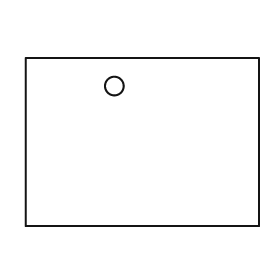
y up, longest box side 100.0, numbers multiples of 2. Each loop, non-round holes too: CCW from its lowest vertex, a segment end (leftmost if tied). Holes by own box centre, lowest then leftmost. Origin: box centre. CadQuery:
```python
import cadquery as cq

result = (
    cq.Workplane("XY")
    .moveTo(-50.0, -36.0)
    .lineTo(50.0, -36.0)
    .lineTo(50.0, 36.0)
    .lineTo(-50.0, 36.0)
    .close()
    .moveTo(-12.0, 24.0)
    .circle(4.0)
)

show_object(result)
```